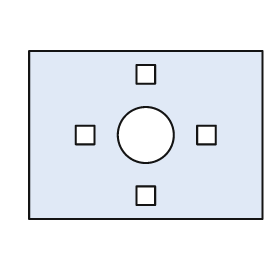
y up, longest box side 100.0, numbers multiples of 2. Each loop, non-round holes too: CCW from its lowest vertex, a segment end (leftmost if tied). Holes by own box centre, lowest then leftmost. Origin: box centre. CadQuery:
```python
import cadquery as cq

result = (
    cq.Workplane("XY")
    .moveTo(-50.0, -36.0)
    .lineTo(50.0, -36.0)
    .lineTo(50.0, 36.0)
    .lineTo(-50.0, 36.0)
    .close()
    .moveTo(-4.0, -30.0)
    .lineTo(4.0, -30.0)
    .lineTo(4.0, -22.0)
    .lineTo(-4.0, -22.0)
    .close()
    .moveTo(-30.0, -4.0)
    .lineTo(-22.0, -4.0)
    .lineTo(-22.0, 4.0)
    .lineTo(-30.0, 4.0)
    .close()
    .moveTo(0.0, 0.0)
    .circle(12.0)
    .moveTo(22.0, -4.0)
    .lineTo(30.0, -4.0)
    .lineTo(30.0, 4.0)
    .lineTo(22.0, 4.0)
    .close()
    .moveTo(-4.0, 22.0)
    .lineTo(4.0, 22.0)
    .lineTo(4.0, 30.0)
    .lineTo(-4.0, 30.0)
    .close()
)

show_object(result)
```